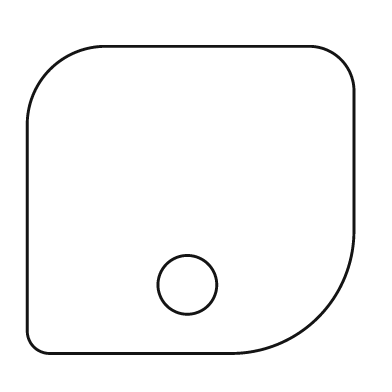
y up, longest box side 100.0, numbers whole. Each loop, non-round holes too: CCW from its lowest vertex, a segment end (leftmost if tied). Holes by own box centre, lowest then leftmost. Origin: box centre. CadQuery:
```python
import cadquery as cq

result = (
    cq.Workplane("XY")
    .moveTo(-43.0, -47.0)
    .lineTo(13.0, -47.0)
    .threePointArc((39.0, -36.0), (50.0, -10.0))
    .lineTo(50.0, 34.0)
    .threePointArc((46.0, 43.0), (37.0, 47.0))
    .lineTo(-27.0, 47.0)
    .threePointArc((-43.0, 40.0), (-50.0, 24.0))
    .lineTo(-50.0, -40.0)
    .threePointArc((-48.0, -45.0), (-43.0, -47.0))
    .close()
    .moveTo(-1.0, -26.0)
    .circle(9.0)
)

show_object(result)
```